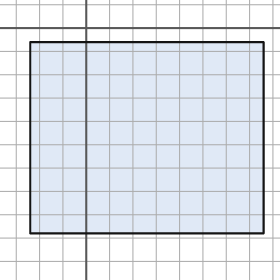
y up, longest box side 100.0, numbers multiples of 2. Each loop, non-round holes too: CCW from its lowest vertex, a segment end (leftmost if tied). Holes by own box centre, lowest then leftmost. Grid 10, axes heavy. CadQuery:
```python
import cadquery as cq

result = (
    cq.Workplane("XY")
    .moveTo(-24.0, -88.0)
    .lineTo(76.0, -88.0)
    .lineTo(76.0, -6.0)
    .lineTo(-24.0, -6.0)
    .close()
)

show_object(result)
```